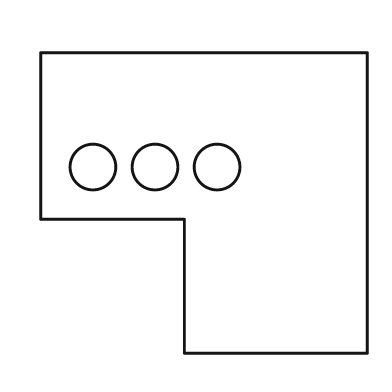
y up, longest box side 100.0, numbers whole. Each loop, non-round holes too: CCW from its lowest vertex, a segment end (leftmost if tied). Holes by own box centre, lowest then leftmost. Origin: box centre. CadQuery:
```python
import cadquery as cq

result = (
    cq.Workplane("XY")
    .moveTo(-6.0, -46.0)
    .lineTo(50.0, -46.0)
    .lineTo(50.0, 46.0)
    .lineTo(-50.0, 46.0)
    .lineTo(-50.0, -5.0)
    .lineTo(-6.0, -5.0)
    .close()
    .moveTo(-34.0, 11.0)
    .circle(7.0)
    .moveTo(-15.0, 11.0)
    .circle(7.0)
    .moveTo(4.0, 11.0)
    .circle(7.0)
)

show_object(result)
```